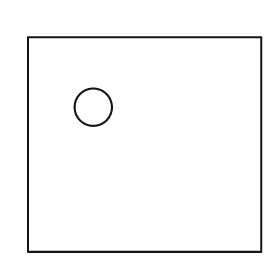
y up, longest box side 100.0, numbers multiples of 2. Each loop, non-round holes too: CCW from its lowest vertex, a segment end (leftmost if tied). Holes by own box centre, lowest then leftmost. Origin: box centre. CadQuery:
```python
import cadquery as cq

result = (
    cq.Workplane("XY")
    .moveTo(-50.0, -46.0)
    .lineTo(50.0, -46.0)
    .lineTo(50.0, 46.0)
    .lineTo(-50.0, 46.0)
    .close()
    .moveTo(-22.0, 16.0)
    .circle(8.0)
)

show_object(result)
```